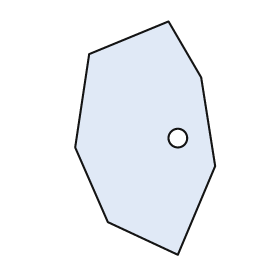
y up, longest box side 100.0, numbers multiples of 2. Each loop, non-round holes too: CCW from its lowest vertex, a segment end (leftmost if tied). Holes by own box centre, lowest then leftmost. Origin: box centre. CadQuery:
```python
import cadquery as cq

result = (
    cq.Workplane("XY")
    .moveTo(14.0, -50.0)
    .lineTo(30.0, -12.0)
    .lineTo(24.0, 26.0)
    .lineTo(10.0, 50.0)
    .lineTo(-24.0, 36.0)
    .lineTo(-30.0, -4.0)
    .lineTo(-16.0, -36.0)
    .close()
    .moveTo(14.0, 0.0)
    .circle(4.0)
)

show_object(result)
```